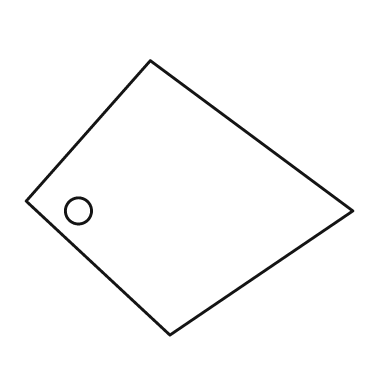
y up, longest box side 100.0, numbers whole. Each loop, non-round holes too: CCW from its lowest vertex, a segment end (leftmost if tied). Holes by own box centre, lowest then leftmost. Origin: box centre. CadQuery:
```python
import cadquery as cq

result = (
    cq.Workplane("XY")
    .moveTo(-6.0, -42.0)
    .lineTo(50.0, -4.0)
    .lineTo(-12.0, 42.0)
    .lineTo(-50.0, -1.0)
    .close()
    .moveTo(-34.0, -4.0)
    .circle(4.0)
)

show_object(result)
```